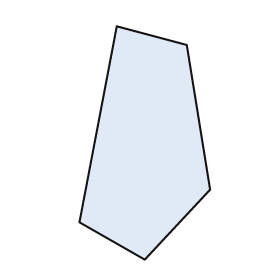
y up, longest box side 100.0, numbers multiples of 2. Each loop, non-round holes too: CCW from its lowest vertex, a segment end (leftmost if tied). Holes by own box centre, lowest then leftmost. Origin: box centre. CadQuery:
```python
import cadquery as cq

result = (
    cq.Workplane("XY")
    .moveTo(0.0, -50.0)
    .lineTo(28.0, -20.0)
    .lineTo(18.0, 42.0)
    .lineTo(-12.0, 50.0)
    .lineTo(-28.0, -34.0)
    .close()
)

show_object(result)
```